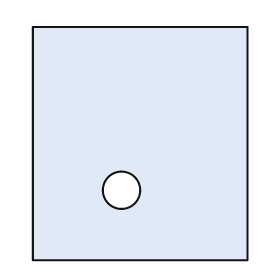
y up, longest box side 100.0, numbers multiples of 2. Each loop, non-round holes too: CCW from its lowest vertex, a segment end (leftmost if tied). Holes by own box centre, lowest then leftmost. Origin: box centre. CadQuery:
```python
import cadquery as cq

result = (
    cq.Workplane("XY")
    .moveTo(-46.0, -50.0)
    .lineTo(46.0, -50.0)
    .lineTo(46.0, 50.0)
    .lineTo(-46.0, 50.0)
    .close()
    .moveTo(-8.0, -20.0)
    .circle(8.0)
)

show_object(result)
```